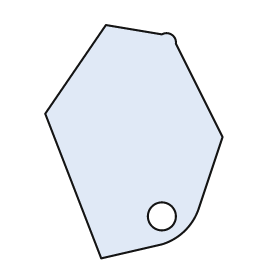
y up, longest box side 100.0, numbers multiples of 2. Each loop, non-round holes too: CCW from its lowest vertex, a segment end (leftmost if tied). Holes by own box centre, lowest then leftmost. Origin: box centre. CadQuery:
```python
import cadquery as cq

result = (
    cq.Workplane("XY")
    .moveTo(-14.0, -50.0)
    .lineTo(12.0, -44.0)
    .threePointArc((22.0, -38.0), (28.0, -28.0))
    .lineTo(38.0, 2.0)
    .lineTo(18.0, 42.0)
    .threePointArc((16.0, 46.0), (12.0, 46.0))
    .lineTo(-12.0, 50.0)
    .lineTo(-38.0, 12.0)
    .close()
    .moveTo(12.0, -32.0)
    .circle(6.0)
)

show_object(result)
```